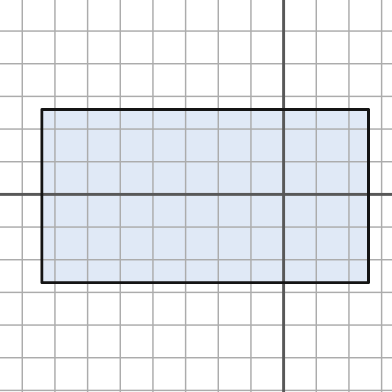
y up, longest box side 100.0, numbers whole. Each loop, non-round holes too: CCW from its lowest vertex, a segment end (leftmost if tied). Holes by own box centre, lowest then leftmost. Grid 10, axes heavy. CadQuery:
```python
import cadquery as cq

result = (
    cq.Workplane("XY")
    .moveTo(-74.0, -27.0)
    .lineTo(26.0, -27.0)
    .lineTo(26.0, 26.0)
    .lineTo(-74.0, 26.0)
    .close()
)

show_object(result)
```